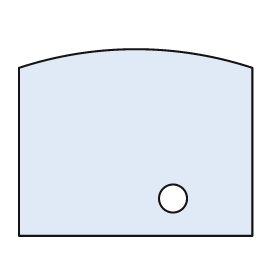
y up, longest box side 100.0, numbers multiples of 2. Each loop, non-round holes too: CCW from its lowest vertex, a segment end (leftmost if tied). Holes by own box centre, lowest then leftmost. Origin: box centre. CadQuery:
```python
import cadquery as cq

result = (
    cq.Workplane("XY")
    .moveTo(-50.0, -40.0)
    .lineTo(50.0, -40.0)
    .lineTo(50.0, 32.0)
    .threePointArc((0.0, 40.0), (-50.0, 32.0))
    .close()
    .moveTo(16.0, -24.0)
    .circle(6.0)
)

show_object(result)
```